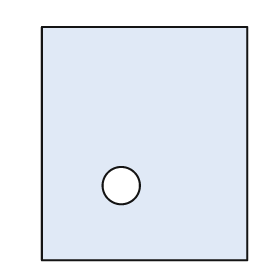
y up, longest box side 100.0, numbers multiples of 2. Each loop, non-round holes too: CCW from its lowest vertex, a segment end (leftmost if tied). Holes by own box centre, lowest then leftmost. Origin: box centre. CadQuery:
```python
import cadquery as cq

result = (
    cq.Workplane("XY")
    .moveTo(-44.0, -50.0)
    .lineTo(44.0, -50.0)
    .lineTo(44.0, 50.0)
    .lineTo(-44.0, 50.0)
    .close()
    .moveTo(-10.0, -18.0)
    .circle(8.0)
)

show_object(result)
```